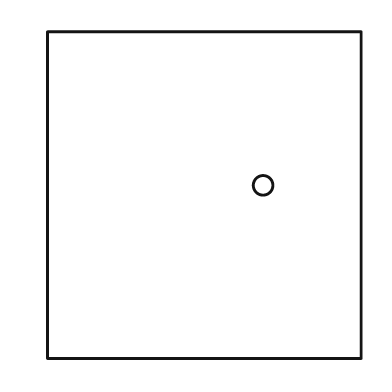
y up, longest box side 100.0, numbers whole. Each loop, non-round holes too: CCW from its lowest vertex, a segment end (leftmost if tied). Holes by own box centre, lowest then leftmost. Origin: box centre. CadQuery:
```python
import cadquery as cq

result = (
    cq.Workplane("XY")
    .moveTo(-48.0, -50.0)
    .lineTo(48.0, -50.0)
    .lineTo(48.0, 50.0)
    .lineTo(-48.0, 50.0)
    .close()
    .moveTo(18.0, 3.0)
    .circle(3.0)
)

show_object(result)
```